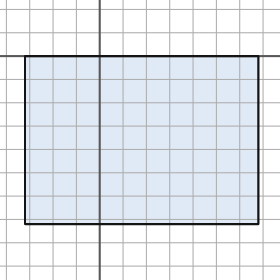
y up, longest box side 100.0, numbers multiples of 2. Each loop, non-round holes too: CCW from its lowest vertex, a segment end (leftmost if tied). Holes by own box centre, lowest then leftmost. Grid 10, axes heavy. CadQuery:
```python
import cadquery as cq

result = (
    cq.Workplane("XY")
    .moveTo(-32.0, -72.0)
    .lineTo(68.0, -72.0)
    .lineTo(68.0, 0.0)
    .lineTo(-32.0, 0.0)
    .close()
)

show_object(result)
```